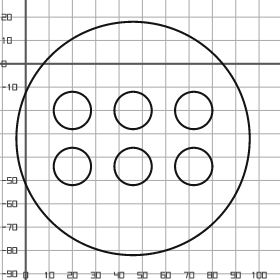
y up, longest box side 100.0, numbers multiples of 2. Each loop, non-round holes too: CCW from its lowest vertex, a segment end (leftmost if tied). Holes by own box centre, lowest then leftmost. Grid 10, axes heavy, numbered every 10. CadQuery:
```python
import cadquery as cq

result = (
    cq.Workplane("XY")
    .moveTo(46.0, -32.0)
    .circle(50.0)
    .moveTo(20.0, -44.0)
    .circle(8.0)
    .moveTo(46.0, -44.0)
    .circle(8.0)
    .moveTo(72.0, -44.0)
    .circle(8.0)
    .moveTo(20.0, -20.0)
    .circle(8.0)
    .moveTo(46.0, -20.0)
    .circle(8.0)
    .moveTo(72.0, -20.0)
    .circle(8.0)
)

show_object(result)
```